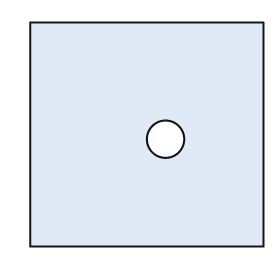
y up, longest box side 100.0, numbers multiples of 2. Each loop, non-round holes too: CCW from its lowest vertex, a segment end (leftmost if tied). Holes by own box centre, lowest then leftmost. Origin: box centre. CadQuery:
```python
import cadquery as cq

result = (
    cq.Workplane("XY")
    .moveTo(-50.0, -48.0)
    .lineTo(50.0, -48.0)
    .lineTo(50.0, 48.0)
    .lineTo(-50.0, 48.0)
    .close()
    .moveTo(8.0, -2.0)
    .circle(8.0)
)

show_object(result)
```